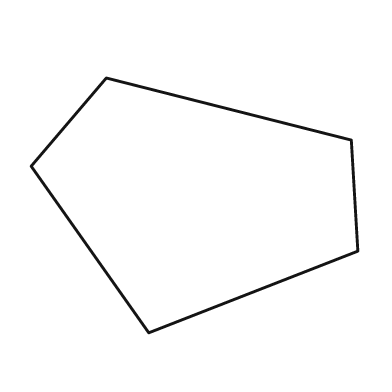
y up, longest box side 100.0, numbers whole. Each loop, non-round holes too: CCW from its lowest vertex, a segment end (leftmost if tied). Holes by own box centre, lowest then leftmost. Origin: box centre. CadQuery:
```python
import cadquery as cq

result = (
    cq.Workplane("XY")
    .moveTo(-14.0, -39.0)
    .lineTo(50.0, -14.0)
    .lineTo(48.0, 20.0)
    .lineTo(-27.0, 39.0)
    .lineTo(-50.0, 12.0)
    .close()
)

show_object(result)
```